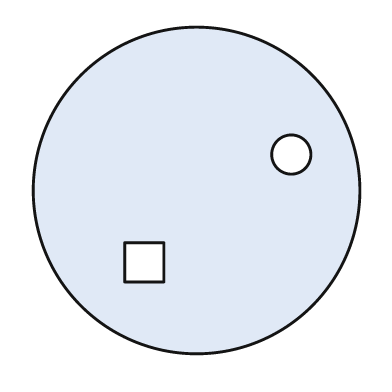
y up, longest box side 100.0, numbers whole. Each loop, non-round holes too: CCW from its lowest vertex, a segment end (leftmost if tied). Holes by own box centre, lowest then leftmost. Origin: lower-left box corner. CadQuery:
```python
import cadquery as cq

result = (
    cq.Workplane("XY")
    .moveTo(50.0, 50.0)
    .circle(50.0)
    .moveTo(28.0, 22.0)
    .lineTo(40.0, 22.0)
    .lineTo(40.0, 34.0)
    .lineTo(28.0, 34.0)
    .close()
    .moveTo(79.0, 61.0)
    .circle(6.0)
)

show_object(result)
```